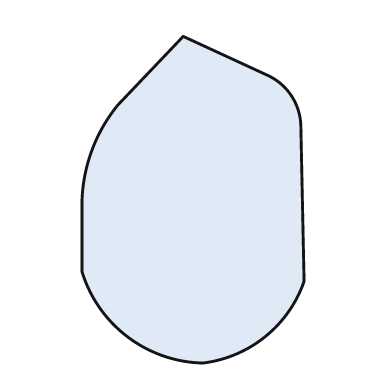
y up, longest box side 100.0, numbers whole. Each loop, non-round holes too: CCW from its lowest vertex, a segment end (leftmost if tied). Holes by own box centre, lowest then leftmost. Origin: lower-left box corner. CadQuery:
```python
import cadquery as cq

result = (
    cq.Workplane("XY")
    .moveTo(37.0, 0.0)
    .threePointArc((56.0, 8.0), (68.0, 25.0))
    .lineTo(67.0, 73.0)
    .threePointArc((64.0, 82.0), (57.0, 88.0))
    .lineTo(31.0, 100.0)
    .lineTo(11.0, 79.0)
    .threePointArc((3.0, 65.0), (0.0, 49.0))
    .lineTo(0.0, 28.0)
    .threePointArc((14.0, 8.0), (37.0, 0.0))
    .close()
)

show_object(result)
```